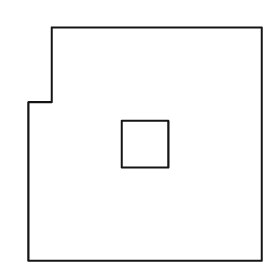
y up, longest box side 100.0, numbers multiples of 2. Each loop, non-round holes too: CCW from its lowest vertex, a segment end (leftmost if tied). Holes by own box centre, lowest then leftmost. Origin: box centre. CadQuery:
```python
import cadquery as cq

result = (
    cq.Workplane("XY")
    .moveTo(-50.0, -50.0)
    .lineTo(50.0, -50.0)
    .lineTo(50.0, 50.0)
    .lineTo(-40.0, 50.0)
    .lineTo(-40.0, 18.0)
    .lineTo(-50.0, 18.0)
    .close()
    .moveTo(-10.0, -10.0)
    .lineTo(10.0, -10.0)
    .lineTo(10.0, 10.0)
    .lineTo(-10.0, 10.0)
    .close()
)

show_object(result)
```